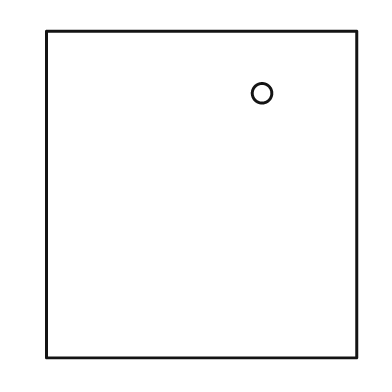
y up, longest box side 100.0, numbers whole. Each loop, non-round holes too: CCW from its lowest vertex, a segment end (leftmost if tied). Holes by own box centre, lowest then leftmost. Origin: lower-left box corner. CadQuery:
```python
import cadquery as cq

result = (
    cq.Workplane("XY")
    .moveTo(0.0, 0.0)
    .lineTo(95.0, 0.0)
    .lineTo(95.0, 100.0)
    .lineTo(0.0, 100.0)
    .close()
    .moveTo(66.0, 81.0)
    .circle(3.0)
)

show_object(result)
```